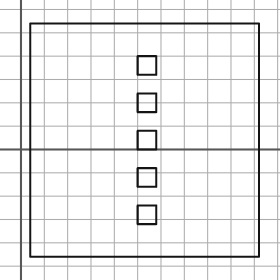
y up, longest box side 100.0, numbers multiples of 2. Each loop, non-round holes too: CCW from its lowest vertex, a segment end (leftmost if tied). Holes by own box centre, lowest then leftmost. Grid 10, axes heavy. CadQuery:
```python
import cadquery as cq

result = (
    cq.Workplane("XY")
    .moveTo(4.0, -46.0)
    .lineTo(102.0, -46.0)
    .lineTo(102.0, 54.0)
    .lineTo(4.0, 54.0)
    .close()
    .moveTo(50.0, -32.0)
    .lineTo(58.0, -32.0)
    .lineTo(58.0, -24.0)
    .lineTo(50.0, -24.0)
    .close()
    .moveTo(50.0, -16.0)
    .lineTo(58.0, -16.0)
    .lineTo(58.0, -8.0)
    .lineTo(50.0, -8.0)
    .close()
    .moveTo(50.0, 0.0)
    .lineTo(58.0, 0.0)
    .lineTo(58.0, 8.0)
    .lineTo(50.0, 8.0)
    .close()
    .moveTo(50.0, 16.0)
    .lineTo(58.0, 16.0)
    .lineTo(58.0, 24.0)
    .lineTo(50.0, 24.0)
    .close()
    .moveTo(50.0, 32.0)
    .lineTo(58.0, 32.0)
    .lineTo(58.0, 40.0)
    .lineTo(50.0, 40.0)
    .close()
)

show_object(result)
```